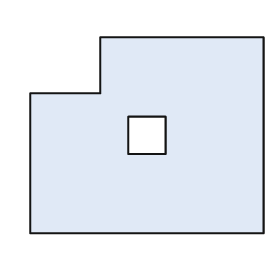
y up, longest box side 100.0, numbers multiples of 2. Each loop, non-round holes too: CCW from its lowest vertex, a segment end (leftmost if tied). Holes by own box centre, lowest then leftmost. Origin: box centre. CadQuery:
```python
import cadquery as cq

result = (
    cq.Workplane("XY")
    .moveTo(-50.0, -42.0)
    .lineTo(50.0, -42.0)
    .lineTo(50.0, 42.0)
    .lineTo(-20.0, 42.0)
    .lineTo(-20.0, 18.0)
    .lineTo(-50.0, 18.0)
    .close()
    .moveTo(-8.0, -8.0)
    .lineTo(8.0, -8.0)
    .lineTo(8.0, 8.0)
    .lineTo(-8.0, 8.0)
    .close()
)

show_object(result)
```